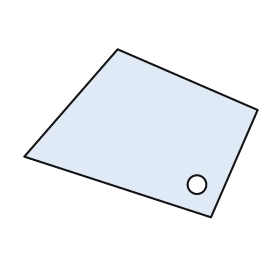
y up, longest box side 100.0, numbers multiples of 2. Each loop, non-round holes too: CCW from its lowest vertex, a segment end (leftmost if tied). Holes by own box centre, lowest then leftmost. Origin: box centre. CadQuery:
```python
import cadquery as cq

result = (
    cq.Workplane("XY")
    .moveTo(30.0, -36.0)
    .lineTo(50.0, 10.0)
    .lineTo(-10.0, 36.0)
    .lineTo(-50.0, -10.0)
    .close()
    .moveTo(24.0, -22.0)
    .circle(4.0)
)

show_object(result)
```